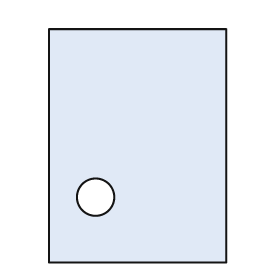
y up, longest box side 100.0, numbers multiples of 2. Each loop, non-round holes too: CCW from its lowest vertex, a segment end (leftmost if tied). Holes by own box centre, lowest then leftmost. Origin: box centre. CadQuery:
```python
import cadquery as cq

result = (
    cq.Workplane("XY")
    .moveTo(-38.0, -50.0)
    .lineTo(38.0, -50.0)
    .lineTo(38.0, 50.0)
    .lineTo(-38.0, 50.0)
    .close()
    .moveTo(-18.0, -22.0)
    .circle(8.0)
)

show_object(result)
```